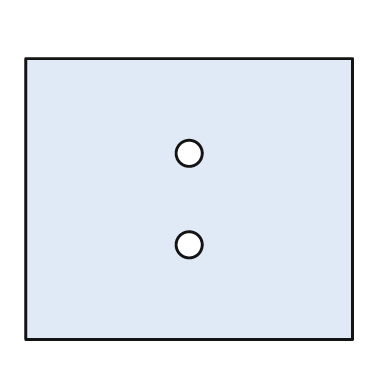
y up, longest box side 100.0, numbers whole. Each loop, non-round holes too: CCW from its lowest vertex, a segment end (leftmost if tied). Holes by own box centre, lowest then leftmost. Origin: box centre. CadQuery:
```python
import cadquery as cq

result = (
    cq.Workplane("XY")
    .moveTo(-50.0, -43.0)
    .lineTo(50.0, -43.0)
    .lineTo(50.0, 43.0)
    .lineTo(-50.0, 43.0)
    .close()
    .moveTo(0.0, -14.0)
    .circle(4.0)
    .moveTo(0.0, 14.0)
    .circle(4.0)
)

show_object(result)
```